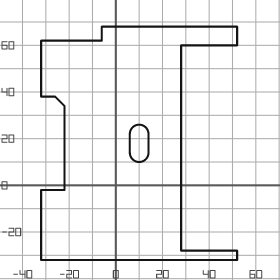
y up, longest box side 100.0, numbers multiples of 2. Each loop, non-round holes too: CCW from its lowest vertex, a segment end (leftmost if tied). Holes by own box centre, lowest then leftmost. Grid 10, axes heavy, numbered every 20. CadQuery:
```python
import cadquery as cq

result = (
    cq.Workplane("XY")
    .moveTo(-32.0, -32.0)
    .lineTo(52.0, -32.0)
    .lineTo(52.0, -28.0)
    .lineTo(28.0, -28.0)
    .lineTo(28.0, 60.0)
    .lineTo(52.0, 60.0)
    .lineTo(52.0, 68.0)
    .lineTo(-6.0, 68.0)
    .lineTo(-6.0, 62.0)
    .lineTo(-32.0, 62.0)
    .lineTo(-32.0, 38.0)
    .lineTo(-26.0, 38.0)
    .lineTo(-22.0, 34.0)
    .lineTo(-22.0, -2.0)
    .lineTo(-32.0, -2.0)
    .close()
    .moveTo(6.0, 14.0)
    .threePointArc((10.0, 10.0), (14.0, 14.0))
    .lineTo(14.0, 22.0)
    .threePointArc((10.0, 26.0), (6.0, 22.0))
    .close()
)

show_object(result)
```